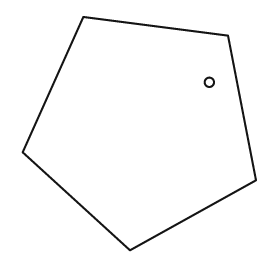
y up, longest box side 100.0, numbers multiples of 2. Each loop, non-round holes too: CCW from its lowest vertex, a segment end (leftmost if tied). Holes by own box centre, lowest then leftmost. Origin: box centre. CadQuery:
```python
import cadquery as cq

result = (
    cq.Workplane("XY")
    .moveTo(-4.0, -50.0)
    .lineTo(50.0, -20.0)
    .lineTo(38.0, 42.0)
    .lineTo(-24.0, 50.0)
    .lineTo(-50.0, -8.0)
    .close()
    .moveTo(30.0, 22.0)
    .circle(2.0)
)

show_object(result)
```